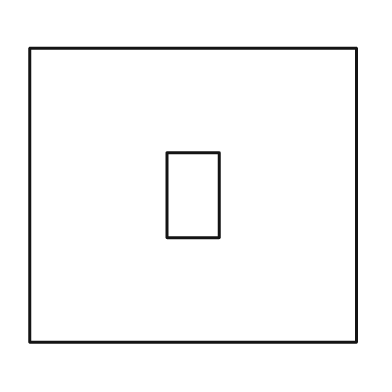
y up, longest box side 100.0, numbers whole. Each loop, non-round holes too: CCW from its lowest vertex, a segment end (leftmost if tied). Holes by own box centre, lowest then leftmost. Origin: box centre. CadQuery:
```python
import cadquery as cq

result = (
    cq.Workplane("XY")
    .moveTo(-50.0, -45.0)
    .lineTo(50.0, -45.0)
    .lineTo(50.0, 45.0)
    .lineTo(-50.0, 45.0)
    .close()
    .moveTo(-8.0, -13.0)
    .lineTo(8.0, -13.0)
    .lineTo(8.0, 13.0)
    .lineTo(-8.0, 13.0)
    .close()
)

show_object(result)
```